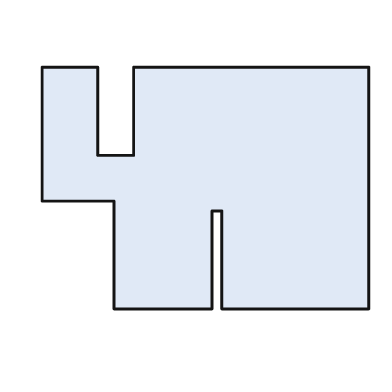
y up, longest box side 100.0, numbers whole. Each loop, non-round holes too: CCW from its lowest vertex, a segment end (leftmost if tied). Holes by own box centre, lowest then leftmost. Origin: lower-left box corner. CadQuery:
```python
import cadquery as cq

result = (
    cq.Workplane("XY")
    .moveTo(22.0, 0.0)
    .lineTo(52.0, 0.0)
    .lineTo(52.0, 30.0)
    .lineTo(55.0, 30.0)
    .lineTo(55.0, 0.0)
    .lineTo(100.0, 0.0)
    .lineTo(100.0, 74.0)
    .lineTo(28.0, 74.0)
    .lineTo(28.0, 47.0)
    .lineTo(17.0, 47.0)
    .lineTo(17.0, 74.0)
    .lineTo(0.0, 74.0)
    .lineTo(0.0, 33.0)
    .lineTo(22.0, 33.0)
    .close()
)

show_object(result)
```